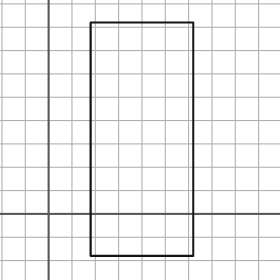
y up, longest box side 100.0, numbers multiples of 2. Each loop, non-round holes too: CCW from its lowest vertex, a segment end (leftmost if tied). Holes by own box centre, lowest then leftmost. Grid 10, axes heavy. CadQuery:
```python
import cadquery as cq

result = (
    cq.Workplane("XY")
    .moveTo(18.0, -18.0)
    .lineTo(62.0, -18.0)
    .lineTo(62.0, 82.0)
    .lineTo(18.0, 82.0)
    .close()
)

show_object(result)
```